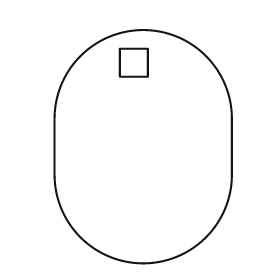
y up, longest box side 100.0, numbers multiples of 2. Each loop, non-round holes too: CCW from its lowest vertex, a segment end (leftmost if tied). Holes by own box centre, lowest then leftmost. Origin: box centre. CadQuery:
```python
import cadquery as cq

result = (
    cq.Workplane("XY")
    .moveTo(-38.0, -12.0)
    .threePointArc((0.0, -50.0), (38.0, -12.0))
    .lineTo(38.0, 12.0)
    .threePointArc((0.0, 50.0), (-38.0, 12.0))
    .close()
    .moveTo(-10.0, 30.0)
    .lineTo(2.0, 30.0)
    .lineTo(2.0, 42.0)
    .lineTo(-10.0, 42.0)
    .close()
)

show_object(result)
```